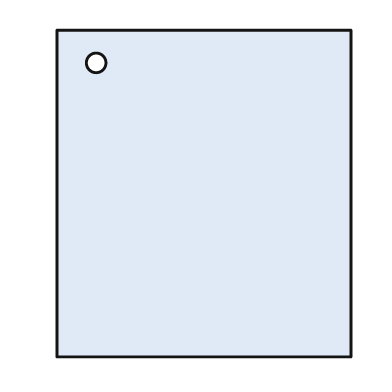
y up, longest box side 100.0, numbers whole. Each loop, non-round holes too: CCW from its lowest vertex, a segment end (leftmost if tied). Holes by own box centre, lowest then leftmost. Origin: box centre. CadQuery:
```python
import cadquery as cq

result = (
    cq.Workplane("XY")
    .moveTo(-45.0, -50.0)
    .lineTo(45.0, -50.0)
    .lineTo(45.0, 50.0)
    .lineTo(-45.0, 50.0)
    .close()
    .moveTo(-33.0, 40.0)
    .circle(3.0)
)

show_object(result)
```